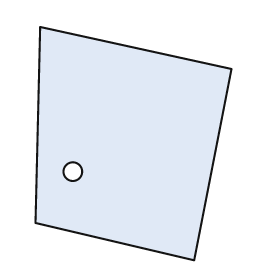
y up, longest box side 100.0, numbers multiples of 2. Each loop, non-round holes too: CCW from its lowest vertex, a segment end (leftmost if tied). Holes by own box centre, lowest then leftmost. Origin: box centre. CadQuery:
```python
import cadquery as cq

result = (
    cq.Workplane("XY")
    .moveTo(26.0, -50.0)
    .lineTo(42.0, 32.0)
    .lineTo(-40.0, 50.0)
    .lineTo(-42.0, -34.0)
    .close()
    .moveTo(-26.0, -12.0)
    .circle(4.0)
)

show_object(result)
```